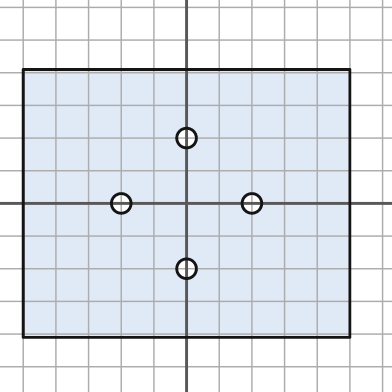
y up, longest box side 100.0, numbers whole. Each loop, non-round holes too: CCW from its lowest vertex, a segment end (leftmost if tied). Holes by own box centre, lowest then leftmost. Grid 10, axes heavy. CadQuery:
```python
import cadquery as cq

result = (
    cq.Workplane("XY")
    .moveTo(-50.0, -41.0)
    .lineTo(50.0, -41.0)
    .lineTo(50.0, 41.0)
    .lineTo(-50.0, 41.0)
    .close()
    .moveTo(0.0, -20.0)
    .circle(3.0)
    .moveTo(-20.0, 0.0)
    .circle(3.0)
    .moveTo(20.0, 0.0)
    .circle(3.0)
    .moveTo(0.0, 20.0)
    .circle(3.0)
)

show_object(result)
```